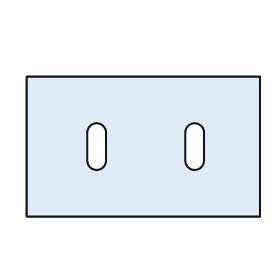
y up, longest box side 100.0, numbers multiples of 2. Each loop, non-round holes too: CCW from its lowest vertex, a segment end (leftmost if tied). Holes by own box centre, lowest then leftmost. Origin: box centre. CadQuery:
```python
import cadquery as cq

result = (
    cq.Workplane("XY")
    .moveTo(-50.0, -30.0)
    .lineTo(50.0, -30.0)
    .lineTo(50.0, 30.0)
    .lineTo(-50.0, 30.0)
    .close()
    .moveTo(-24.0, -6.0)
    .threePointArc((-20.0, -10.0), (-16.0, -6.0))
    .lineTo(-16.0, 6.0)
    .threePointArc((-20.0, 10.0), (-24.0, 6.0))
    .close()
    .moveTo(18.0, -6.0)
    .threePointArc((22.0, -10.0), (26.0, -6.0))
    .lineTo(26.0, 6.0)
    .threePointArc((22.0, 10.0), (18.0, 6.0))
    .close()
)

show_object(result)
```